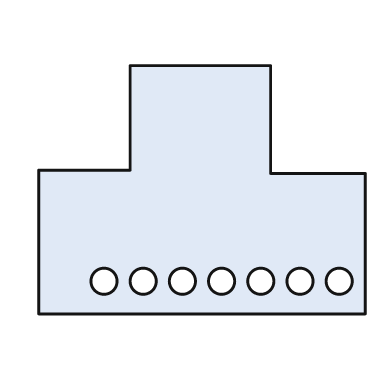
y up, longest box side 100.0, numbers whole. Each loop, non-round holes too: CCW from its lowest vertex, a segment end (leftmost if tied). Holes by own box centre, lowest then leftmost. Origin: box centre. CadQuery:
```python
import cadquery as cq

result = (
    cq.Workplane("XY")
    .moveTo(-50.0, -38.0)
    .lineTo(50.0, -38.0)
    .lineTo(50.0, 5.0)
    .lineTo(21.0, 5.0)
    .lineTo(21.0, 38.0)
    .lineTo(-22.0, 38.0)
    .lineTo(-22.0, 6.0)
    .lineTo(-50.0, 6.0)
    .close()
    .moveTo(-30.0, -28.0)
    .circle(4.0)
    .moveTo(-18.0, -28.0)
    .circle(4.0)
    .moveTo(-6.0, -28.0)
    .circle(4.0)
    .moveTo(6.0, -28.0)
    .circle(4.0)
    .moveTo(18.0, -28.0)
    .circle(4.0)
    .moveTo(30.0, -28.0)
    .circle(4.0)
    .moveTo(42.0, -28.0)
    .circle(4.0)
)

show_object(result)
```